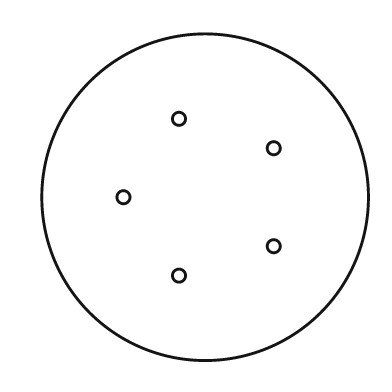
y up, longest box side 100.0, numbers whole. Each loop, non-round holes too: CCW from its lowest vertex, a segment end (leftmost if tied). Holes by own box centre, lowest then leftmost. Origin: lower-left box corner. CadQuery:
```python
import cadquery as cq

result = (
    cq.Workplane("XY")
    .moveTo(50.0, 50.0)
    .circle(50.0)
    .moveTo(42.0, 26.0)
    .circle(2.0)
    .moveTo(71.0, 35.0)
    .circle(2.0)
    .moveTo(25.0, 50.0)
    .circle(2.0)
    .moveTo(71.0, 65.0)
    .circle(2.0)
    .moveTo(42.0, 74.0)
    .circle(2.0)
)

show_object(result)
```